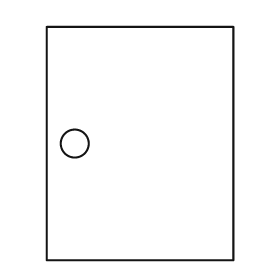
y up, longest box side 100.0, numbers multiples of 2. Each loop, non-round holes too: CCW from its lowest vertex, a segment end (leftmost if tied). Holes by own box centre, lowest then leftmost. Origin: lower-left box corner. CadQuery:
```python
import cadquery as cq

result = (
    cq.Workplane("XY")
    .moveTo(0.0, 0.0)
    .lineTo(80.0, 0.0)
    .lineTo(80.0, 100.0)
    .lineTo(0.0, 100.0)
    .close()
    .moveTo(12.0, 50.0)
    .circle(6.0)
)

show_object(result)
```